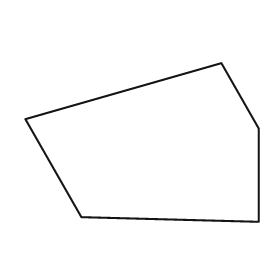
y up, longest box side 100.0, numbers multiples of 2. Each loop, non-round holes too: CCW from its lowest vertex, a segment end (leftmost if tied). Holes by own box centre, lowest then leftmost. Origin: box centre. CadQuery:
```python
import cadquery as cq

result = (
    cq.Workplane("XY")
    .moveTo(50.0, -34.0)
    .lineTo(50.0, 6.0)
    .lineTo(34.0, 34.0)
    .lineTo(-50.0, 10.0)
    .lineTo(-26.0, -32.0)
    .close()
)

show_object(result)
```